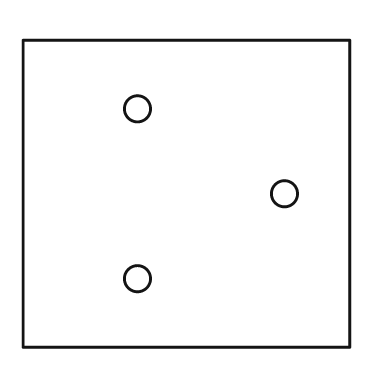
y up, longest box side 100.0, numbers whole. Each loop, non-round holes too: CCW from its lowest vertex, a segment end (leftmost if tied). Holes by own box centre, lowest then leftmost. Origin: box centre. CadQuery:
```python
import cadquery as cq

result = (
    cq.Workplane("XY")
    .moveTo(-50.0, -47.0)
    .lineTo(50.0, -47.0)
    .lineTo(50.0, 47.0)
    .lineTo(-50.0, 47.0)
    .close()
    .moveTo(-15.0, -26.0)
    .circle(4.0)
    .moveTo(30.0, 0.0)
    .circle(4.0)
    .moveTo(-15.0, 26.0)
    .circle(4.0)
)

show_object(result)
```